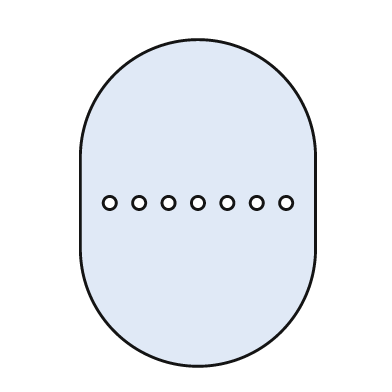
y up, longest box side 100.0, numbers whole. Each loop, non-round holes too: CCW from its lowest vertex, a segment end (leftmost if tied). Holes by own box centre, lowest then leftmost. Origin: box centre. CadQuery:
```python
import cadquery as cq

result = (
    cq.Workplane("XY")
    .moveTo(-36.0, -14.0)
    .threePointArc((0.0, -50.0), (36.0, -14.0))
    .lineTo(36.0, 14.0)
    .threePointArc((0.0, 50.0), (-36.0, 14.0))
    .close()
    .moveTo(-27.0, 0.0)
    .circle(2.0)
    .moveTo(-18.0, 0.0)
    .circle(2.0)
    .moveTo(-9.0, 0.0)
    .circle(2.0)
    .moveTo(0.0, 0.0)
    .circle(2.0)
    .moveTo(9.0, 0.0)
    .circle(2.0)
    .moveTo(18.0, 0.0)
    .circle(2.0)
    .moveTo(27.0, 0.0)
    .circle(2.0)
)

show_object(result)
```